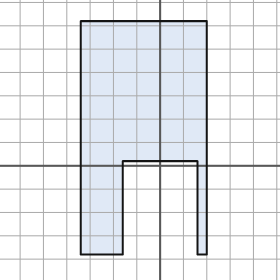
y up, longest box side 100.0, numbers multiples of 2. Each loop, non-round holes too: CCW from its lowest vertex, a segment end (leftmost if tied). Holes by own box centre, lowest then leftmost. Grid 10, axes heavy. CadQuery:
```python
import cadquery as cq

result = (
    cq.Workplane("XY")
    .moveTo(-34.0, -38.0)
    .lineTo(-16.0, -38.0)
    .lineTo(-16.0, 2.0)
    .lineTo(16.0, 2.0)
    .lineTo(16.0, -38.0)
    .lineTo(20.0, -38.0)
    .lineTo(20.0, 62.0)
    .lineTo(-34.0, 62.0)
    .close()
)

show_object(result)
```